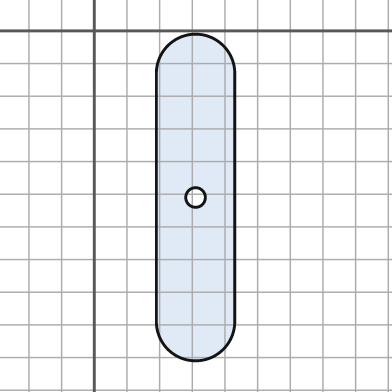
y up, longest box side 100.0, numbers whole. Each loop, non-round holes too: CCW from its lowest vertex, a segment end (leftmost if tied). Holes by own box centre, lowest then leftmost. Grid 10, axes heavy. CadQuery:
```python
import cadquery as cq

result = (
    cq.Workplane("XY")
    .moveTo(19.0, -89.0)
    .threePointArc((31.0, -101.0), (43.0, -89.0))
    .lineTo(43.0, -13.0)
    .threePointArc((31.0, -1.0), (19.0, -13.0))
    .close()
    .moveTo(31.0, -51.0)
    .circle(3.0)
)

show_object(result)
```